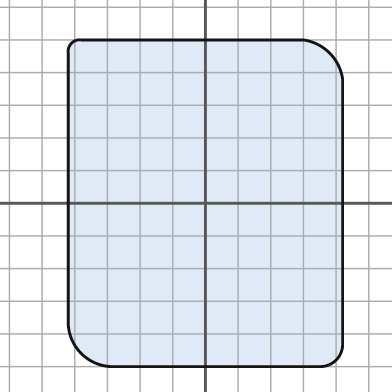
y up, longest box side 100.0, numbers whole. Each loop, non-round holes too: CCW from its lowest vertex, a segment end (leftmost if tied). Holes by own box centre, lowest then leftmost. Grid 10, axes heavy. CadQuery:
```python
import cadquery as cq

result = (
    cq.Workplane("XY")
    .moveTo(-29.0, -50.0)
    .lineTo(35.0, -50.0)
    .threePointArc((40.0, -48.0), (42.0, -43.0))
    .lineTo(42.0, 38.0)
    .threePointArc((38.0, 46.0), (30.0, 50.0))
    .lineTo(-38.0, 50.0)
    .threePointArc((-41.0, 49.0), (-42.0, 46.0))
    .lineTo(-42.0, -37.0)
    .threePointArc((-38.0, -46.0), (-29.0, -50.0))
    .close()
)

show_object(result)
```